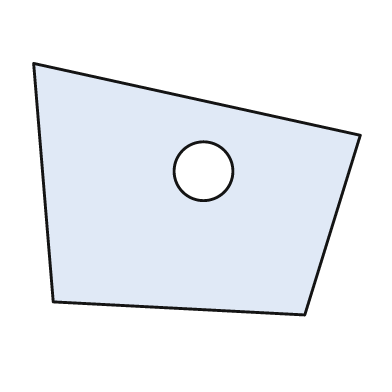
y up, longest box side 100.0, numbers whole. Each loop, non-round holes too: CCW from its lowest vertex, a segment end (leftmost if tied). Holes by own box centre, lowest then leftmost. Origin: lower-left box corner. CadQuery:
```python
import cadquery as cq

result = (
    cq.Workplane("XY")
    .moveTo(83.0, 0.0)
    .lineTo(100.0, 55.0)
    .lineTo(0.0, 77.0)
    .lineTo(6.0, 4.0)
    .close()
    .moveTo(52.0, 44.0)
    .circle(9.0)
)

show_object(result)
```